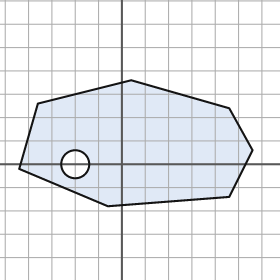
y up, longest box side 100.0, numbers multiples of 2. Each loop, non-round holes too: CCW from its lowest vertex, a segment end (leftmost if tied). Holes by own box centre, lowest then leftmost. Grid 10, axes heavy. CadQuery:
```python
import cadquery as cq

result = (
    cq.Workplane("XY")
    .moveTo(-6.0, -18.0)
    .lineTo(46.0, -14.0)
    .lineTo(56.0, 6.0)
    .lineTo(46.0, 24.0)
    .lineTo(4.0, 36.0)
    .lineTo(-36.0, 26.0)
    .lineTo(-44.0, -2.0)
    .close()
    .moveTo(-20.0, 0.0)
    .circle(6.0)
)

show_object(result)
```